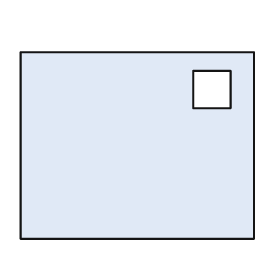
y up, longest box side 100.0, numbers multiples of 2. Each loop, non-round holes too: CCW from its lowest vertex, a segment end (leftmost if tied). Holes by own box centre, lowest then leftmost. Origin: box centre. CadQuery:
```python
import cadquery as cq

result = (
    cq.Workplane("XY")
    .moveTo(-50.0, -40.0)
    .lineTo(50.0, -40.0)
    .lineTo(50.0, 40.0)
    .lineTo(-50.0, 40.0)
    .close()
    .moveTo(24.0, 16.0)
    .lineTo(40.0, 16.0)
    .lineTo(40.0, 32.0)
    .lineTo(24.0, 32.0)
    .close()
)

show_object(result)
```